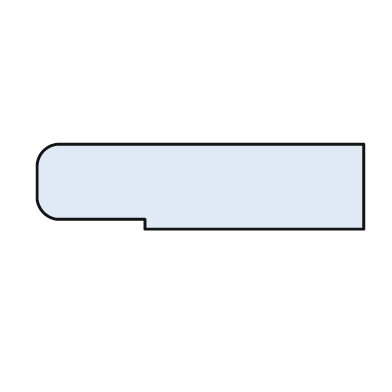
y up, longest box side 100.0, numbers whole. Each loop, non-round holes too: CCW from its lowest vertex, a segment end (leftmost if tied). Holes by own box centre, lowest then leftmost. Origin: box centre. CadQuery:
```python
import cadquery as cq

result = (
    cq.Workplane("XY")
    .moveTo(-17.0, -13.0)
    .lineTo(50.0, -13.0)
    .lineTo(50.0, 13.0)
    .lineTo(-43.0, 13.0)
    .threePointArc((-48.0, 11.0), (-50.0, 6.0))
    .lineTo(-50.0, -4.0)
    .threePointArc((-48.0, -8.0), (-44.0, -10.0))
    .lineTo(-17.0, -10.0)
    .close()
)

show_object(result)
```